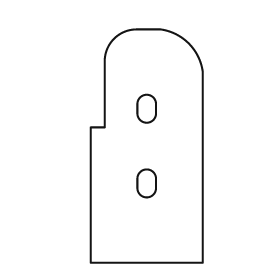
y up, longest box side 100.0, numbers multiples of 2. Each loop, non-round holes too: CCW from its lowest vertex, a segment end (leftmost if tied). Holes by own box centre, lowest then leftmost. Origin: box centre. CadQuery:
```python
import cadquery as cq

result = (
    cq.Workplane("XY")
    .moveTo(-24.0, -50.0)
    .lineTo(24.0, -50.0)
    .lineTo(24.0, 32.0)
    .threePointArc((18.0, 44.0), (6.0, 50.0))
    .lineTo(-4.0, 50.0)
    .threePointArc((-14.0, 46.0), (-18.0, 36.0))
    .lineTo(-18.0, 8.0)
    .lineTo(-24.0, 8.0)
    .close()
    .moveTo(-4.0, -18.0)
    .threePointArc((0.0, -22.0), (4.0, -18.0))
    .lineTo(4.0, -14.0)
    .threePointArc((0.0, -10.0), (-4.0, -14.0))
    .close()
    .moveTo(-4.0, 14.0)
    .threePointArc((0.0, 10.0), (4.0, 14.0))
    .lineTo(4.0, 18.0)
    .threePointArc((0.0, 22.0), (-4.0, 18.0))
    .close()
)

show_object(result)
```